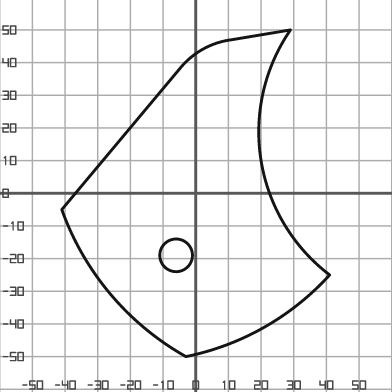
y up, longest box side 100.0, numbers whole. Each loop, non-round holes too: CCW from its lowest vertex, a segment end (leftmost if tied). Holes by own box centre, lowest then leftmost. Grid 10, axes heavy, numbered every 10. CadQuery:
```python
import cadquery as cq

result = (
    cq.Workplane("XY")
    .moveTo(-3.0, -50.0)
    .threePointArc((21.0, -41.0), (41.0, -25.0))
    .threePointArc((20.0, 10.0), (29.0, 50.0))
    .lineTo(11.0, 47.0)
    .threePointArc((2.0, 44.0), (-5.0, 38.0))
    .lineTo(-41.0, -5.0)
    .threePointArc((-26.0, -31.0), (-3.0, -50.0))
    .close()
    .moveTo(-6.0, -19.0)
    .circle(5.0)
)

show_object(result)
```